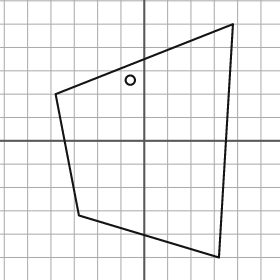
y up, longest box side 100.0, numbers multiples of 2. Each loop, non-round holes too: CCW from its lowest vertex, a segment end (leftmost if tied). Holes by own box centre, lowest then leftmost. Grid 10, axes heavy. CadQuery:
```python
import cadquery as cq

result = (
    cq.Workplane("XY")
    .moveTo(32.0, -50.0)
    .lineTo(38.0, 50.0)
    .lineTo(-38.0, 20.0)
    .lineTo(-28.0, -32.0)
    .close()
    .moveTo(-6.0, 26.0)
    .circle(2.0)
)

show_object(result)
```